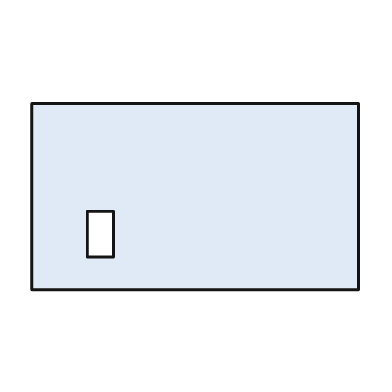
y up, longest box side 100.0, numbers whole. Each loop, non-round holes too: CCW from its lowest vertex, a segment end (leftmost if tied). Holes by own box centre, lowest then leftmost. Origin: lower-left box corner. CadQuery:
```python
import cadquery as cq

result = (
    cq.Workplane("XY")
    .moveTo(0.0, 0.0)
    .lineTo(100.0, 0.0)
    .lineTo(100.0, 57.0)
    .lineTo(0.0, 57.0)
    .close()
    .moveTo(17.0, 10.0)
    .lineTo(25.0, 10.0)
    .lineTo(25.0, 24.0)
    .lineTo(17.0, 24.0)
    .close()
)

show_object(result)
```